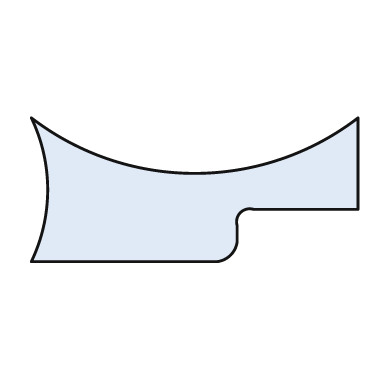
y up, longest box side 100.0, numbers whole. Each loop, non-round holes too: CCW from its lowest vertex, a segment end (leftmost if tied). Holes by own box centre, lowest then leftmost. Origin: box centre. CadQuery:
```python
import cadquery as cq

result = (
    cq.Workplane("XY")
    .moveTo(-50.0, -22.0)
    .lineTo(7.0, -22.0)
    .threePointArc((11.0, -20.0), (13.0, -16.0))
    .lineTo(13.0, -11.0)
    .threePointArc((14.0, -7.0), (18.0, -6.0))
    .lineTo(50.0, -6.0)
    .lineTo(50.0, 22.0)
    .threePointArc((0.0, 5.0), (-50.0, 22.0))
    .threePointArc((-45.0, 0.0), (-50.0, -22.0))
    .close()
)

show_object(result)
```